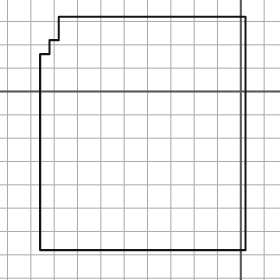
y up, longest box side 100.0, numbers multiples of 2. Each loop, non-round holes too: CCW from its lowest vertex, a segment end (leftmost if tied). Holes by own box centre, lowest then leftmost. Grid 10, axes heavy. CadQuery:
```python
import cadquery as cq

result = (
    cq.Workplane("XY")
    .moveTo(-86.0, -68.0)
    .lineTo(2.0, -68.0)
    .lineTo(2.0, 32.0)
    .lineTo(-78.0, 32.0)
    .lineTo(-78.0, 22.0)
    .lineTo(-82.0, 22.0)
    .lineTo(-82.0, 16.0)
    .lineTo(-86.0, 16.0)
    .close()
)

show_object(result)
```